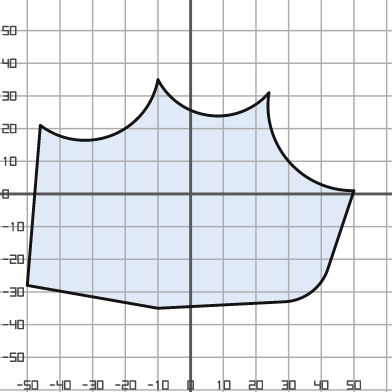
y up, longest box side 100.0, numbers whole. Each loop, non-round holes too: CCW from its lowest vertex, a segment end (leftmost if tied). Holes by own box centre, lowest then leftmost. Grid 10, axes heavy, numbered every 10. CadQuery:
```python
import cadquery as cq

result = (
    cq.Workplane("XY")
    .moveTo(-10.0, -35.0)
    .lineTo(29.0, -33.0)
    .threePointArc((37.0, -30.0), (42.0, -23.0))
    .lineTo(50.0, 1.0)
    .threePointArc((30.0, 10.0), (24.0, 31.0))
    .threePointArc((6.0, 24.0), (-10.0, 35.0))
    .threePointArc((-24.0, 18.0), (-46.0, 21.0))
    .lineTo(-50.0, -28.0)
    .close()
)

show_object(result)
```